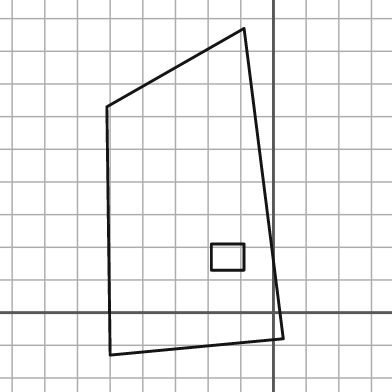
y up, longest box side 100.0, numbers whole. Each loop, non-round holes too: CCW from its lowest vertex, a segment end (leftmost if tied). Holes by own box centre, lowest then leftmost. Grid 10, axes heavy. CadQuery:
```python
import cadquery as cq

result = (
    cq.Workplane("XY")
    .moveTo(-50.0, -13.0)
    .lineTo(3.0, -8.0)
    .lineTo(-9.0, 87.0)
    .lineTo(-51.0, 63.0)
    .close()
    .moveTo(-19.0, 13.0)
    .lineTo(-9.0, 13.0)
    .lineTo(-9.0, 21.0)
    .lineTo(-19.0, 21.0)
    .close()
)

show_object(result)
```